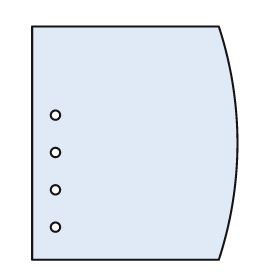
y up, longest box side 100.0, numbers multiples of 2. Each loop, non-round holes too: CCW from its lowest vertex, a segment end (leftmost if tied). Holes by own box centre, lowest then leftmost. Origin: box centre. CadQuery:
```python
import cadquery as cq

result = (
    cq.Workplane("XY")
    .moveTo(-44.0, -50.0)
    .lineTo(36.0, -50.0)
    .threePointArc((44.0, 0.0), (36.0, 50.0))
    .lineTo(-44.0, 50.0)
    .close()
    .moveTo(-34.0, -36.0)
    .circle(2.0)
    .moveTo(-34.0, -20.0)
    .circle(2.0)
    .moveTo(-34.0, -4.0)
    .circle(2.0)
    .moveTo(-34.0, 12.0)
    .circle(2.0)
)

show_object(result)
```